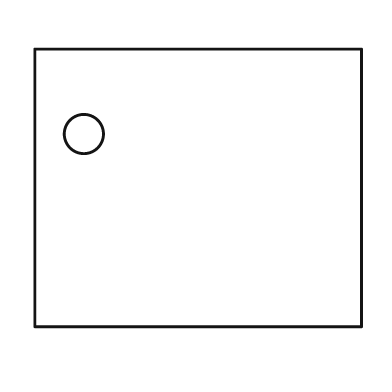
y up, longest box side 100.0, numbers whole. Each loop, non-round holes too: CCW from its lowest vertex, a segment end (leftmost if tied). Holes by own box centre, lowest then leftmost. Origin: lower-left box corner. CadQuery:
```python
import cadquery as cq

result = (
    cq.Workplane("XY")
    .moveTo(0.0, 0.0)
    .lineTo(100.0, 0.0)
    .lineTo(100.0, 85.0)
    .lineTo(0.0, 85.0)
    .close()
    .moveTo(15.0, 59.0)
    .circle(6.0)
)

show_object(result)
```